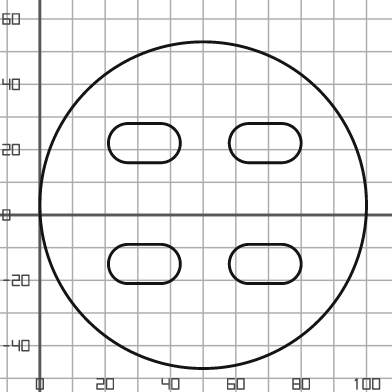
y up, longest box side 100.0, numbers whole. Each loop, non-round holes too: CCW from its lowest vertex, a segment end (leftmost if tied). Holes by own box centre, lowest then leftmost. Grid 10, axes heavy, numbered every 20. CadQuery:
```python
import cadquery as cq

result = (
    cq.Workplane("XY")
    .moveTo(50.0, 3.0)
    .circle(50.0)
    .moveTo(27.0, -21.0)
    .lineTo(37.0, -21.0)
    .threePointArc((43.0, -15.0), (37.0, -9.0))
    .lineTo(27.0, -9.0)
    .threePointArc((21.0, -15.0), (27.0, -21.0))
    .close()
    .moveTo(64.0, -21.0)
    .lineTo(74.0, -21.0)
    .threePointArc((80.0, -15.0), (74.0, -9.0))
    .lineTo(64.0, -9.0)
    .threePointArc((58.0, -15.0), (64.0, -21.0))
    .close()
    .moveTo(27.0, 16.0)
    .lineTo(37.0, 16.0)
    .threePointArc((43.0, 22.0), (37.0, 28.0))
    .lineTo(27.0, 28.0)
    .threePointArc((21.0, 22.0), (27.0, 16.0))
    .close()
    .moveTo(64.0, 16.0)
    .lineTo(74.0, 16.0)
    .threePointArc((80.0, 22.0), (74.0, 28.0))
    .lineTo(64.0, 28.0)
    .threePointArc((58.0, 22.0), (64.0, 16.0))
    .close()
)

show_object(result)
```